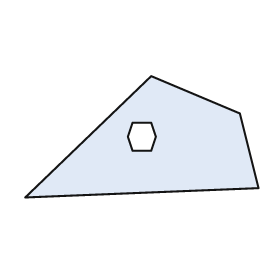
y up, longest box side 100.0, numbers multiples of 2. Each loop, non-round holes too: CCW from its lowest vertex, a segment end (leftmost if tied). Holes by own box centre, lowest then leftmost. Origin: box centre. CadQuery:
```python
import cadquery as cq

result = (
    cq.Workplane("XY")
    .moveTo(-50.0, -26.0)
    .lineTo(50.0, -22.0)
    .lineTo(42.0, 10.0)
    .lineTo(4.0, 26.0)
    .close()
    .moveTo(-4.0, -6.0)
    .lineTo(4.0, -6.0)
    .lineTo(6.0, 0.0)
    .lineTo(4.0, 6.0)
    .lineTo(-4.0, 6.0)
    .lineTo(-6.0, 0.0)
    .close()
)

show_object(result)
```